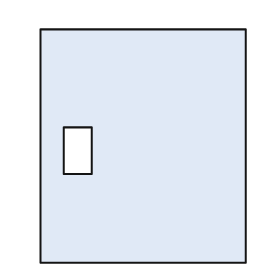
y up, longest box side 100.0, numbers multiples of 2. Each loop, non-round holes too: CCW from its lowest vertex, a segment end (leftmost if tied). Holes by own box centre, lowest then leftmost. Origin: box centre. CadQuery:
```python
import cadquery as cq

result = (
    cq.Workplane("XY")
    .moveTo(-44.0, -50.0)
    .lineTo(44.0, -50.0)
    .lineTo(44.0, 50.0)
    .lineTo(-44.0, 50.0)
    .close()
    .moveTo(-34.0, -12.0)
    .lineTo(-22.0, -12.0)
    .lineTo(-22.0, 8.0)
    .lineTo(-34.0, 8.0)
    .close()
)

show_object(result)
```